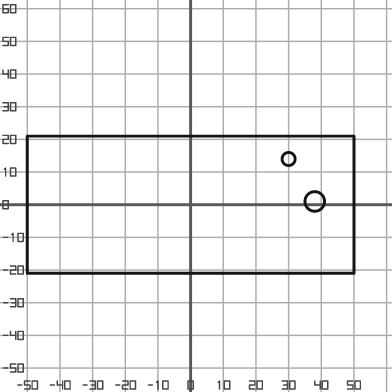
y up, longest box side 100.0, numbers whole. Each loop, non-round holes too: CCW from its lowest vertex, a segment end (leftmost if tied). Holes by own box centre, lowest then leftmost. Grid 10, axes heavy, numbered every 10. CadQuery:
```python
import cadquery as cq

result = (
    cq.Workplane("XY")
    .moveTo(-50.0, -21.0)
    .lineTo(50.0, -21.0)
    .lineTo(50.0, 21.0)
    .lineTo(-50.0, 21.0)
    .close()
    .moveTo(38.0, 1.0)
    .circle(3.0)
    .moveTo(30.0, 14.0)
    .circle(2.0)
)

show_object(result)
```